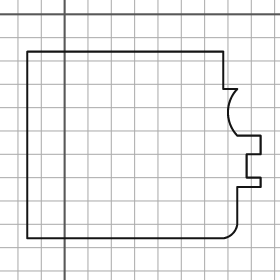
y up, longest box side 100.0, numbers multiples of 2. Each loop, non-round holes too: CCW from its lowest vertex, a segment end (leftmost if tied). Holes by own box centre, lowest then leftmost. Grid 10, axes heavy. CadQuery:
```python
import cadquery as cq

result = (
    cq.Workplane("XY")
    .moveTo(-16.0, -96.0)
    .lineTo(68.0, -96.0)
    .threePointArc((72.0, -94.0), (74.0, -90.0))
    .lineTo(74.0, -74.0)
    .lineTo(84.0, -74.0)
    .lineTo(84.0, -70.0)
    .lineTo(78.0, -70.0)
    .lineTo(78.0, -60.0)
    .lineTo(84.0, -60.0)
    .lineTo(84.0, -52.0)
    .lineTo(74.0, -52.0)
    .threePointArc((70.0, -42.0), (74.0, -32.0))
    .lineTo(68.0, -32.0)
    .lineTo(68.0, -16.0)
    .lineTo(-16.0, -16.0)
    .close()
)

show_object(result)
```